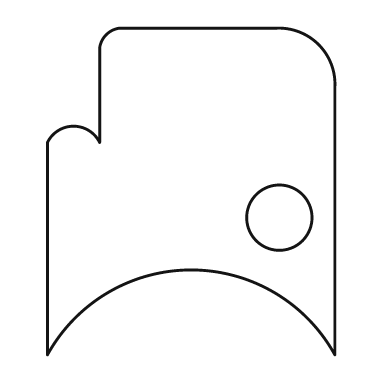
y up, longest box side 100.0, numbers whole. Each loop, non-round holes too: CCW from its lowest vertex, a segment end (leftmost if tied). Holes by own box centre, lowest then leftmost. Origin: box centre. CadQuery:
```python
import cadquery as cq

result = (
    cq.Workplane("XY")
    .moveTo(-44.0, -50.0)
    .threePointArc((0.0, -24.0), (44.0, -50.0))
    .lineTo(44.0, 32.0)
    .threePointArc((39.0, 45.0), (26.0, 50.0))
    .lineTo(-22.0, 50.0)
    .threePointArc((-26.0, 48.0), (-28.0, 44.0))
    .lineTo(-28.0, 15.0)
    .threePointArc((-36.0, 20.0), (-44.0, 15.0))
    .close()
    .moveTo(27.0, -8.0)
    .circle(10.0)
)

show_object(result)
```